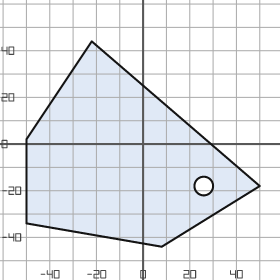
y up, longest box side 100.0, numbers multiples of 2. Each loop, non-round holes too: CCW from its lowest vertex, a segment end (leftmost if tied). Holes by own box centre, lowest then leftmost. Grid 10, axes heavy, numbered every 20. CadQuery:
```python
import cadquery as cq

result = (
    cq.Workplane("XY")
    .moveTo(8.0, -44.0)
    .lineTo(50.0, -18.0)
    .lineTo(-22.0, 44.0)
    .lineTo(-50.0, 2.0)
    .lineTo(-50.0, -34.0)
    .close()
    .moveTo(26.0, -18.0)
    .circle(4.0)
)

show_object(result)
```